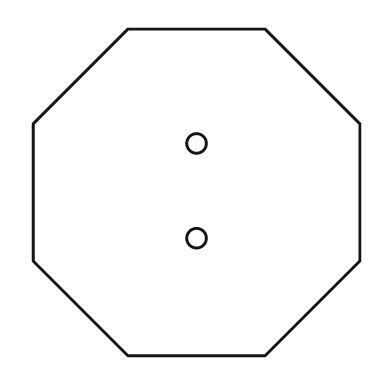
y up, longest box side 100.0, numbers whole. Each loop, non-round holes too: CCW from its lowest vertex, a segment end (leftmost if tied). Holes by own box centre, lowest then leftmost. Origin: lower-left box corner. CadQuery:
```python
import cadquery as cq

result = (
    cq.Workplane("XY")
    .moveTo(29.0, 0.0)
    .lineTo(71.0, 0.0)
    .lineTo(100.0, 29.0)
    .lineTo(100.0, 71.0)
    .lineTo(71.0, 100.0)
    .lineTo(29.0, 100.0)
    .lineTo(0.0, 71.0)
    .lineTo(0.0, 29.0)
    .close()
    .moveTo(50.0, 36.0)
    .circle(3.0)
    .moveTo(50.0, 65.0)
    .circle(3.0)
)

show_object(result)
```